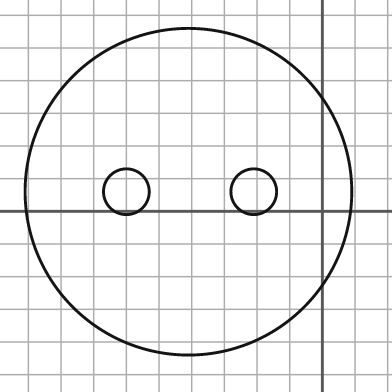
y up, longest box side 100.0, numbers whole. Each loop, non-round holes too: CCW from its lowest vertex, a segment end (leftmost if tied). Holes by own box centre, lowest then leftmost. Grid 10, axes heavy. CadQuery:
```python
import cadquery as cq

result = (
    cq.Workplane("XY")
    .moveTo(-41.0, 6.0)
    .circle(50.0)
    .moveTo(-60.0, 6.0)
    .circle(7.0)
    .moveTo(-21.0, 6.0)
    .circle(7.0)
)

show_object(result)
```